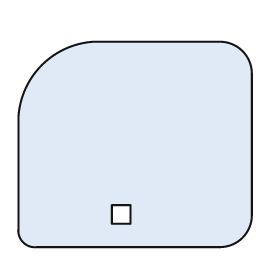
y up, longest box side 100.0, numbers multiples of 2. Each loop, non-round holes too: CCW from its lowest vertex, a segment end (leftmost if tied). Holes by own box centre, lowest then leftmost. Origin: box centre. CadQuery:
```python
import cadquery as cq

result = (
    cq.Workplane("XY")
    .moveTo(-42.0, -44.0)
    .lineTo(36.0, -44.0)
    .threePointArc((46.0, -40.0), (50.0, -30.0))
    .lineTo(50.0, 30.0)
    .threePointArc((46.0, 40.0), (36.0, 44.0))
    .lineTo(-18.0, 44.0)
    .threePointArc((-40.0, 34.0), (-50.0, 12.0))
    .lineTo(-50.0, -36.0)
    .threePointArc((-48.0, -42.0), (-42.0, -44.0))
    .close()
    .moveTo(-10.0, -34.0)
    .lineTo(-2.0, -34.0)
    .lineTo(-2.0, -26.0)
    .lineTo(-10.0, -26.0)
    .close()
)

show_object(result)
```